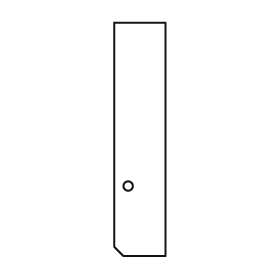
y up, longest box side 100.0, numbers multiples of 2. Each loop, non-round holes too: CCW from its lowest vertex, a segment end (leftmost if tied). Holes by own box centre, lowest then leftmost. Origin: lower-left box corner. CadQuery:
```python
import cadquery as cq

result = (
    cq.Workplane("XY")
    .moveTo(4.0, 0.0)
    .lineTo(22.0, 0.0)
    .lineTo(22.0, 100.0)
    .lineTo(0.0, 100.0)
    .lineTo(0.0, 4.0)
    .close()
    .moveTo(6.0, 30.0)
    .circle(2.0)
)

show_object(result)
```